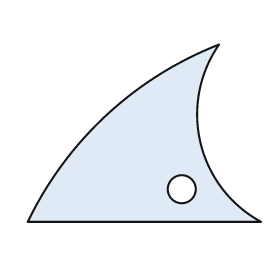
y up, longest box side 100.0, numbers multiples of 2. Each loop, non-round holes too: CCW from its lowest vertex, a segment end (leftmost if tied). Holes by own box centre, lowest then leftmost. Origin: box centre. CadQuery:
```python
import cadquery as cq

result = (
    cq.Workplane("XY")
    .moveTo(-50.0, -38.0)
    .lineTo(50.0, -38.0)
    .threePointArc((24.0, -4.0), (32.0, 38.0))
    .threePointArc((-16.0, 8.0), (-50.0, -38.0))
    .close()
    .moveTo(16.0, -24.0)
    .circle(6.0)
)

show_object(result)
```